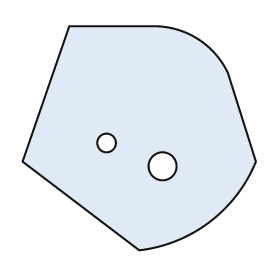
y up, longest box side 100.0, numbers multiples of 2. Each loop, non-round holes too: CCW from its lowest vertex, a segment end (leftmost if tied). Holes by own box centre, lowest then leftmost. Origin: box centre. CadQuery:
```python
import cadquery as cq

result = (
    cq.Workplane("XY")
    .moveTo(0.0, -48.0)
    .threePointArc((30.0, -36.0), (50.0, -10.0))
    .lineTo(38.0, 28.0)
    .threePointArc((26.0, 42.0), (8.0, 48.0))
    .lineTo(-30.0, 48.0)
    .lineTo(-50.0, -10.0)
    .close()
    .moveTo(10.0, -12.0)
    .circle(6.0)
    .moveTo(-14.0, -2.0)
    .circle(4.0)
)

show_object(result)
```